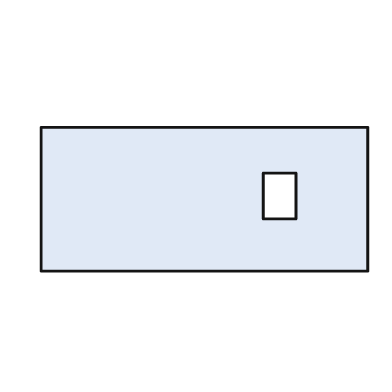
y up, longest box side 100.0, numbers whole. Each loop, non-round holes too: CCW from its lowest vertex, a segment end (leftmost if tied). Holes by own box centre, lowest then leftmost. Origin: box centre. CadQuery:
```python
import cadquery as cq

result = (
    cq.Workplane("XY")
    .moveTo(-50.0, -22.0)
    .lineTo(50.0, -22.0)
    .lineTo(50.0, 22.0)
    .lineTo(-50.0, 22.0)
    .close()
    .moveTo(18.0, -6.0)
    .lineTo(28.0, -6.0)
    .lineTo(28.0, 8.0)
    .lineTo(18.0, 8.0)
    .close()
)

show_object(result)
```